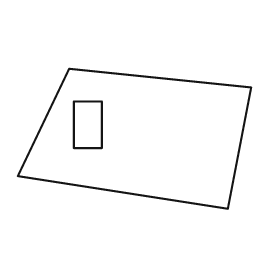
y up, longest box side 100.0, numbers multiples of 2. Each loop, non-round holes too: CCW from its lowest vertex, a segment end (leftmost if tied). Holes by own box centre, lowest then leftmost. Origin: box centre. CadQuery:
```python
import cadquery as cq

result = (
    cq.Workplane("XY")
    .moveTo(40.0, -30.0)
    .lineTo(50.0, 22.0)
    .lineTo(-28.0, 30.0)
    .lineTo(-50.0, -16.0)
    .close()
    .moveTo(-26.0, -4.0)
    .lineTo(-14.0, -4.0)
    .lineTo(-14.0, 16.0)
    .lineTo(-26.0, 16.0)
    .close()
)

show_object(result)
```